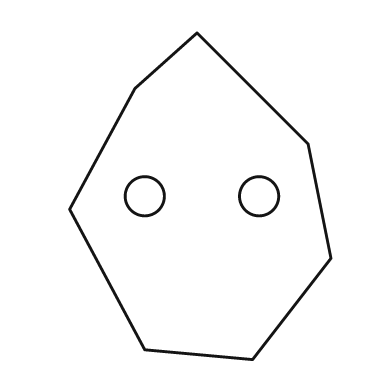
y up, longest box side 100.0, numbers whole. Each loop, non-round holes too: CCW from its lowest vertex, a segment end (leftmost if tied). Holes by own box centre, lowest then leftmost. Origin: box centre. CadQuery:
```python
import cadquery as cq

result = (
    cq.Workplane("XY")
    .moveTo(16.0, -50.0)
    .lineTo(40.0, -19.0)
    .lineTo(33.0, 16.0)
    .lineTo(-1.0, 50.0)
    .lineTo(-20.0, 33.0)
    .lineTo(-40.0, -4.0)
    .lineTo(-17.0, -47.0)
    .close()
    .moveTo(-17.0, 0.0)
    .circle(6.0)
    .moveTo(18.0, 0.0)
    .circle(6.0)
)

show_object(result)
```